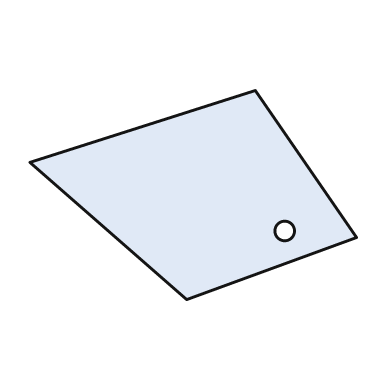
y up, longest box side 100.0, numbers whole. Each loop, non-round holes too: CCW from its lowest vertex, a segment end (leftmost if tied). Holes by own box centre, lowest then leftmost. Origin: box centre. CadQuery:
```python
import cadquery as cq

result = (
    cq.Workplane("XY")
    .moveTo(-2.0, -32.0)
    .lineTo(50.0, -13.0)
    .lineTo(19.0, 32.0)
    .lineTo(-50.0, 10.0)
    .close()
    .moveTo(28.0, -11.0)
    .circle(3.0)
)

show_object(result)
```